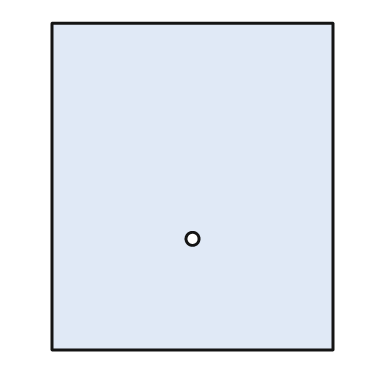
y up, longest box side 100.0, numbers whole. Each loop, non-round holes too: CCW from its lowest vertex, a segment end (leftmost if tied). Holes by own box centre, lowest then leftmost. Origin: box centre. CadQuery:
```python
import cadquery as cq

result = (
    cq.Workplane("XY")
    .moveTo(-43.0, -50.0)
    .lineTo(43.0, -50.0)
    .lineTo(43.0, 50.0)
    .lineTo(-43.0, 50.0)
    .close()
    .moveTo(0.0, -16.0)
    .circle(2.0)
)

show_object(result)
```